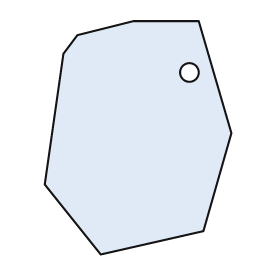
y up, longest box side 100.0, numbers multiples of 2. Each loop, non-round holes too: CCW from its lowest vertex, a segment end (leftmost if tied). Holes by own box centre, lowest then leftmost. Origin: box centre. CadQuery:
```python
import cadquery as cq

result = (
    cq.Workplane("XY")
    .moveTo(-16.0, -50.0)
    .lineTo(28.0, -40.0)
    .lineTo(40.0, 2.0)
    .lineTo(26.0, 50.0)
    .lineTo(-2.0, 50.0)
    .lineTo(-26.0, 44.0)
    .lineTo(-32.0, 36.0)
    .lineTo(-40.0, -20.0)
    .close()
    .moveTo(22.0, 28.0)
    .circle(4.0)
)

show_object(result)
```